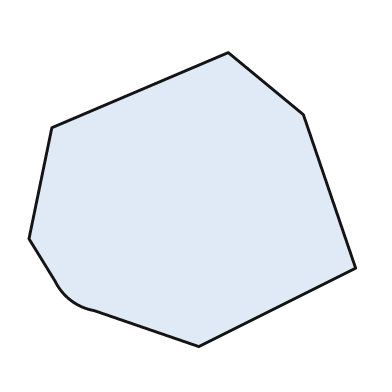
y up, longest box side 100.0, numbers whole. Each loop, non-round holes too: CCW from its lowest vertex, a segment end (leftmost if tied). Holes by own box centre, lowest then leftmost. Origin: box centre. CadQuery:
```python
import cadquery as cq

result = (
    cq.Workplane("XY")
    .moveTo(2.0, -45.0)
    .lineTo(50.0, -21.0)
    .lineTo(34.0, 26.0)
    .lineTo(11.0, 45.0)
    .lineTo(-43.0, 22.0)
    .lineTo(-50.0, -12.0)
    .lineTo(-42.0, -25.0)
    .threePointArc((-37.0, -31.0), (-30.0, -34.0))
    .close()
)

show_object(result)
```